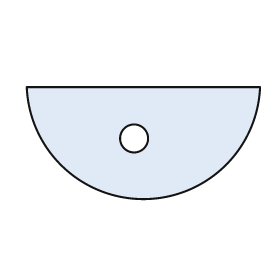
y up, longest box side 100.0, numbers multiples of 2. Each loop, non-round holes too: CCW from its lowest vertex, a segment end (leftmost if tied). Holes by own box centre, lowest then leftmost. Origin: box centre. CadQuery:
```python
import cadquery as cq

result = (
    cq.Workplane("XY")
    .moveTo(-50.0, 24.0)
    .threePointArc((0.0, -24.0), (50.0, 24.0))
    .close()
    .moveTo(-4.0, 2.0)
    .circle(6.0)
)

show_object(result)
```